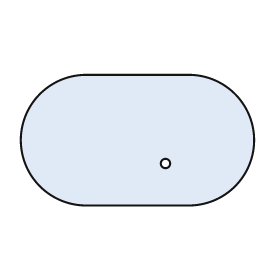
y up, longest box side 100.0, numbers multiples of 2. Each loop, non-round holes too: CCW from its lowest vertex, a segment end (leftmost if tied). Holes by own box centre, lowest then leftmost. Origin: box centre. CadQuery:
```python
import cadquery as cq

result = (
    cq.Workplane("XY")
    .moveTo(-22.0, -28.0)
    .lineTo(22.0, -28.0)
    .threePointArc((50.0, 0.0), (22.0, 28.0))
    .lineTo(-22.0, 28.0)
    .threePointArc((-50.0, 0.0), (-22.0, -28.0))
    .close()
    .moveTo(12.0, -10.0)
    .circle(2.0)
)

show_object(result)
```